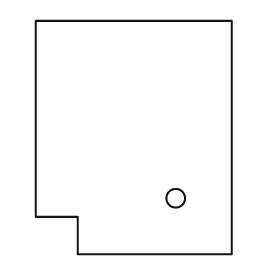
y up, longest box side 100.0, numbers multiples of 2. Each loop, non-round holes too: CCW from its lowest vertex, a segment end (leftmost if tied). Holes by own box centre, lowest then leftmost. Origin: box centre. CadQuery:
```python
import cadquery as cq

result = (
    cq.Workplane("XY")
    .moveTo(-24.0, -50.0)
    .lineTo(42.0, -50.0)
    .lineTo(42.0, 50.0)
    .lineTo(-42.0, 50.0)
    .lineTo(-42.0, -34.0)
    .lineTo(-24.0, -34.0)
    .close()
    .moveTo(18.0, -26.0)
    .circle(4.0)
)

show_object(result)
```